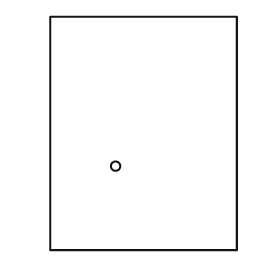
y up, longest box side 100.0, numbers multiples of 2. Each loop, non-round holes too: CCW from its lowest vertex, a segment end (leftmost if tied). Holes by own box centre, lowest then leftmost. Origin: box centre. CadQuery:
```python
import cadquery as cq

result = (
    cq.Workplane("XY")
    .moveTo(-40.0, -50.0)
    .lineTo(40.0, -50.0)
    .lineTo(40.0, 50.0)
    .lineTo(-40.0, 50.0)
    .close()
    .moveTo(-12.0, -14.0)
    .circle(2.0)
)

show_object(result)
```